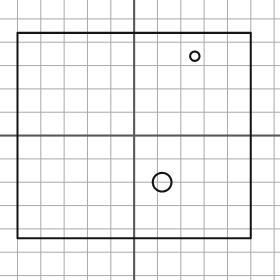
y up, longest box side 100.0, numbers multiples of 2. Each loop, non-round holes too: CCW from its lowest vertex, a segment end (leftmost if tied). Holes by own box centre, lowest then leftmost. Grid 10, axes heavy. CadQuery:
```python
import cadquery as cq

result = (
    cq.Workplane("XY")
    .moveTo(-50.0, -44.0)
    .lineTo(50.0, -44.0)
    .lineTo(50.0, 44.0)
    .lineTo(-50.0, 44.0)
    .close()
    .moveTo(12.0, -20.0)
    .circle(4.0)
    .moveTo(26.0, 34.0)
    .circle(2.0)
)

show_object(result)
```